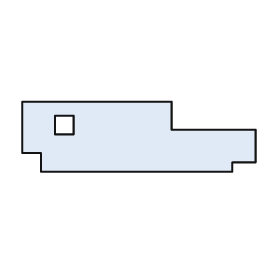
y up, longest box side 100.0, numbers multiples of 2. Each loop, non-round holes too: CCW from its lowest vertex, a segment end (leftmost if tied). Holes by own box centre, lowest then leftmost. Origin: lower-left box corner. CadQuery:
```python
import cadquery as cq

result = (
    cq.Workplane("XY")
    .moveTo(8.0, 0.0)
    .lineTo(90.0, 0.0)
    .lineTo(90.0, 4.0)
    .lineTo(100.0, 4.0)
    .lineTo(100.0, 18.0)
    .lineTo(64.0, 18.0)
    .lineTo(64.0, 30.0)
    .lineTo(0.0, 30.0)
    .lineTo(0.0, 8.0)
    .lineTo(8.0, 8.0)
    .close()
    .moveTo(14.0, 16.0)
    .lineTo(22.0, 16.0)
    .lineTo(22.0, 24.0)
    .lineTo(14.0, 24.0)
    .close()
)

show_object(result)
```